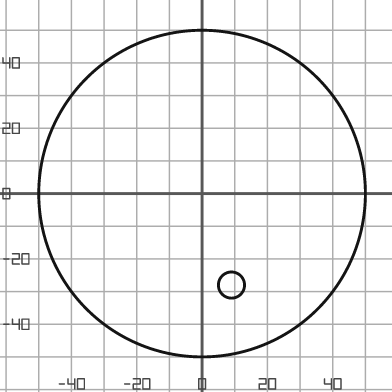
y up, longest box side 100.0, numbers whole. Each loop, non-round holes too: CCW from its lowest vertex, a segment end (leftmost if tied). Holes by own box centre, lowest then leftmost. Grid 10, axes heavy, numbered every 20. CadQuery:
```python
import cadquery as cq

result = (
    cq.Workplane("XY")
    .moveTo(0.0, 0.0)
    .circle(50.0)
    .moveTo(9.0, -28.0)
    .circle(4.0)
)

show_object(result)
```